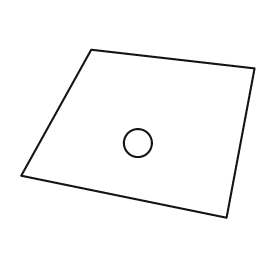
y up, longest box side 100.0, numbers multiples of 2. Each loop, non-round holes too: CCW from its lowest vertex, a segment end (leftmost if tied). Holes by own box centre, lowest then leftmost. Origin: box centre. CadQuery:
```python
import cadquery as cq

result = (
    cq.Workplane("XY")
    .moveTo(38.0, -36.0)
    .lineTo(50.0, 28.0)
    .lineTo(-20.0, 36.0)
    .lineTo(-50.0, -18.0)
    .close()
    .moveTo(0.0, -4.0)
    .circle(6.0)
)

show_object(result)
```